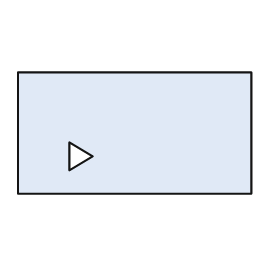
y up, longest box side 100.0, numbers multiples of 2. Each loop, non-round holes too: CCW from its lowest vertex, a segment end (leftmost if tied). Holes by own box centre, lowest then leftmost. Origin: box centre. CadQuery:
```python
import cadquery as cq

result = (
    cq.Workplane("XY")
    .moveTo(-50.0, -26.0)
    .lineTo(50.0, -26.0)
    .lineTo(50.0, 26.0)
    .lineTo(-50.0, 26.0)
    .close()
    .moveTo(-28.0, -16.0)
    .lineTo(-18.0, -10.0)
    .lineTo(-28.0, -4.0)
    .close()
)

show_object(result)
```